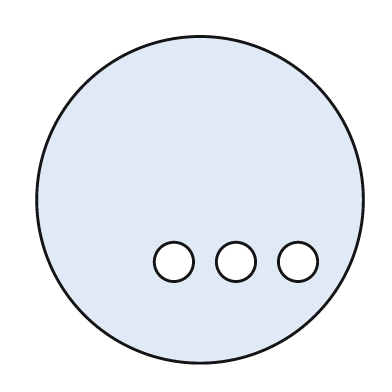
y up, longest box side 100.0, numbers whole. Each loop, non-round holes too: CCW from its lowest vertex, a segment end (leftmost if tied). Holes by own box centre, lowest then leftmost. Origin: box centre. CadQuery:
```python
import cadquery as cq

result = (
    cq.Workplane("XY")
    .moveTo(0.0, 0.0)
    .circle(50.0)
    .moveTo(-8.0, -19.0)
    .circle(6.0)
    .moveTo(11.0, -19.0)
    .circle(6.0)
    .moveTo(30.0, -19.0)
    .circle(6.0)
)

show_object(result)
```